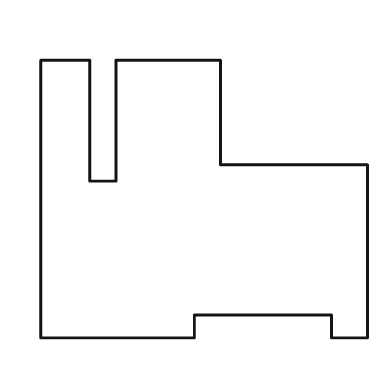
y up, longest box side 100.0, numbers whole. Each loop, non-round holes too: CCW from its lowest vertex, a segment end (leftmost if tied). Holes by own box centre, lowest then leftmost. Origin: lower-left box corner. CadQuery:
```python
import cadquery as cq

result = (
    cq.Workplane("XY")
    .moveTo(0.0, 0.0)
    .lineTo(47.0, 0.0)
    .lineTo(47.0, 7.0)
    .lineTo(89.0, 7.0)
    .lineTo(89.0, 0.0)
    .lineTo(100.0, 0.0)
    .lineTo(100.0, 53.0)
    .lineTo(55.0, 53.0)
    .lineTo(55.0, 85.0)
    .lineTo(23.0, 85.0)
    .lineTo(23.0, 48.0)
    .lineTo(15.0, 48.0)
    .lineTo(15.0, 85.0)
    .lineTo(0.0, 85.0)
    .close()
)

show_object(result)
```